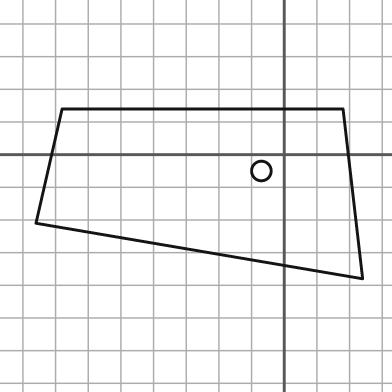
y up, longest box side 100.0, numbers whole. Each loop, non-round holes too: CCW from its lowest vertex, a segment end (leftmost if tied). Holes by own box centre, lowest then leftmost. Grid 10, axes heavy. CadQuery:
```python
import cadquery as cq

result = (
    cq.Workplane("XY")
    .moveTo(24.0, -38.0)
    .lineTo(18.0, 14.0)
    .lineTo(-68.0, 14.0)
    .lineTo(-76.0, -21.0)
    .close()
    .moveTo(-7.0, -5.0)
    .circle(3.0)
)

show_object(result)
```